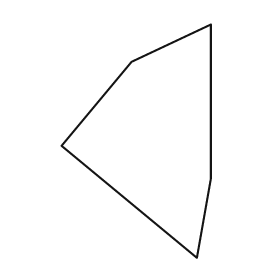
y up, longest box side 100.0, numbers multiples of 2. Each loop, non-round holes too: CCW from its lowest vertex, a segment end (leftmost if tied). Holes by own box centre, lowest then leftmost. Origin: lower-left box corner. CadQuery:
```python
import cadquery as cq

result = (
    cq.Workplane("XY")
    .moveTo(58.0, 0.0)
    .lineTo(64.0, 34.0)
    .lineTo(64.0, 100.0)
    .lineTo(30.0, 84.0)
    .lineTo(0.0, 48.0)
    .close()
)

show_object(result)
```